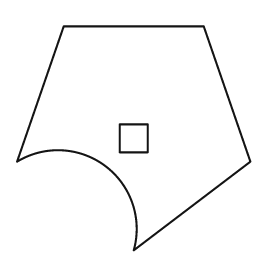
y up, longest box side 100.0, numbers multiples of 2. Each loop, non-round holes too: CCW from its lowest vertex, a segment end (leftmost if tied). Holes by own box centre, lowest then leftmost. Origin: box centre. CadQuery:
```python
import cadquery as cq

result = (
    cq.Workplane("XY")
    .moveTo(0.0, -48.0)
    .lineTo(50.0, -10.0)
    .lineTo(30.0, 48.0)
    .lineTo(-30.0, 48.0)
    .lineTo(-50.0, -10.0)
    .threePointArc((-12.0, -12.0), (0.0, -48.0))
    .close()
    .moveTo(-6.0, -6.0)
    .lineTo(6.0, -6.0)
    .lineTo(6.0, 6.0)
    .lineTo(-6.0, 6.0)
    .close()
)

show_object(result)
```